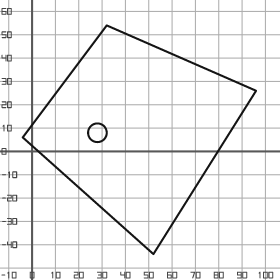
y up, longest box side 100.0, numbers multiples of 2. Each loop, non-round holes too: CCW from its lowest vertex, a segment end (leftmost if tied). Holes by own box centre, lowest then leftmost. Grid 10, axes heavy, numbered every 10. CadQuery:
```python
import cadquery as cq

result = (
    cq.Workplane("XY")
    .moveTo(52.0, -44.0)
    .lineTo(96.0, 26.0)
    .lineTo(32.0, 54.0)
    .lineTo(-4.0, 6.0)
    .close()
    .moveTo(28.0, 8.0)
    .circle(4.0)
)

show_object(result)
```